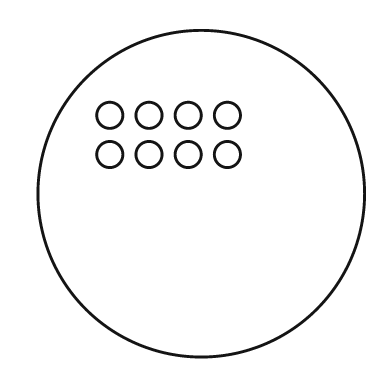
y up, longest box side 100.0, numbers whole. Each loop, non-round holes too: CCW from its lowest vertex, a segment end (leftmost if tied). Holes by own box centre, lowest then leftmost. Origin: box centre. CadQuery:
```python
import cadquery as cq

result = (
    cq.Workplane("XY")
    .moveTo(0.0, 0.0)
    .circle(50.0)
    .moveTo(-28.0, 12.0)
    .circle(4.0)
    .moveTo(-16.0, 12.0)
    .circle(4.0)
    .moveTo(-4.0, 12.0)
    .circle(4.0)
    .moveTo(8.0, 12.0)
    .circle(4.0)
    .moveTo(-28.0, 24.0)
    .circle(4.0)
    .moveTo(-16.0, 24.0)
    .circle(4.0)
    .moveTo(-4.0, 24.0)
    .circle(4.0)
    .moveTo(8.0, 24.0)
    .circle(4.0)
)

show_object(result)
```